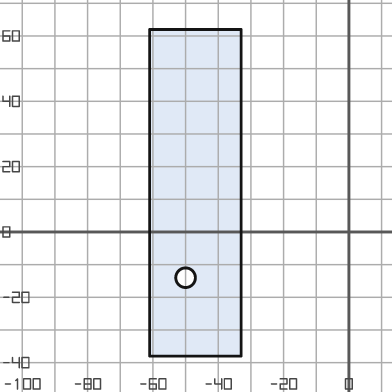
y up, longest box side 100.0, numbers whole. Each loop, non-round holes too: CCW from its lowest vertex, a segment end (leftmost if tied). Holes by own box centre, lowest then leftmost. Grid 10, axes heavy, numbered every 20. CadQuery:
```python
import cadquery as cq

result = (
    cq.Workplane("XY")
    .moveTo(-61.0, -38.0)
    .lineTo(-33.0, -38.0)
    .lineTo(-33.0, 62.0)
    .lineTo(-61.0, 62.0)
    .close()
    .moveTo(-50.0, -14.0)
    .circle(3.0)
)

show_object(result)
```